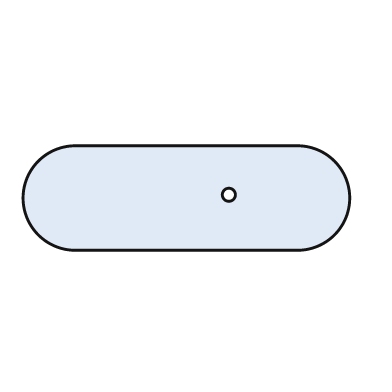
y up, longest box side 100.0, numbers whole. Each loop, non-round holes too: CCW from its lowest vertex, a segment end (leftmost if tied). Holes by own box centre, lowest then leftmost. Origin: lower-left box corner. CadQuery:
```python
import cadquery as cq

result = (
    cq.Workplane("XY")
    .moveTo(16.0, 0.0)
    .lineTo(84.0, 0.0)
    .threePointArc((100.0, 16.0), (84.0, 32.0))
    .lineTo(16.0, 32.0)
    .threePointArc((0.0, 16.0), (16.0, 0.0))
    .close()
    .moveTo(63.0, 17.0)
    .circle(2.0)
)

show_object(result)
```